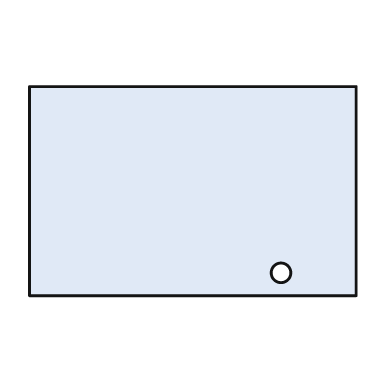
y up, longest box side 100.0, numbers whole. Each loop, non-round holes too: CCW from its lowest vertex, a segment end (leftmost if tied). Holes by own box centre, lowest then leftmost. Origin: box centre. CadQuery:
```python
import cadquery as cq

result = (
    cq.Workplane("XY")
    .moveTo(-50.0, -32.0)
    .lineTo(50.0, -32.0)
    .lineTo(50.0, 32.0)
    .lineTo(-50.0, 32.0)
    .close()
    .moveTo(27.0, -25.0)
    .circle(3.0)
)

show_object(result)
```